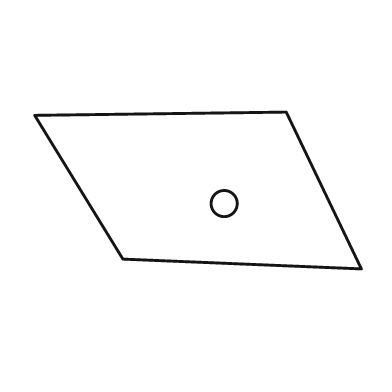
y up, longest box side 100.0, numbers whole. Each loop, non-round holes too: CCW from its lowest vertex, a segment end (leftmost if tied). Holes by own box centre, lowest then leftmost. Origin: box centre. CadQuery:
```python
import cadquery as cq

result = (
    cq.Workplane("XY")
    .moveTo(50.0, -24.0)
    .lineTo(27.0, 24.0)
    .lineTo(-50.0, 23.0)
    .lineTo(-23.0, -21.0)
    .close()
    .moveTo(8.0, -4.0)
    .circle(4.0)
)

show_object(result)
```